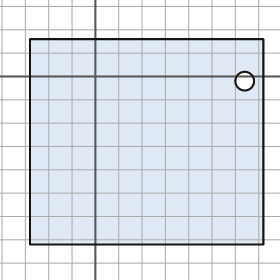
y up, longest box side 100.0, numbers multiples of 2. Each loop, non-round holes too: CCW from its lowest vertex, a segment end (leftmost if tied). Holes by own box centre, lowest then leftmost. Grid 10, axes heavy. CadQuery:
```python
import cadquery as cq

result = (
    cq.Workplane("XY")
    .moveTo(-28.0, -72.0)
    .lineTo(72.0, -72.0)
    .lineTo(72.0, 16.0)
    .lineTo(-28.0, 16.0)
    .close()
    .moveTo(64.0, -2.0)
    .circle(4.0)
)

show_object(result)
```